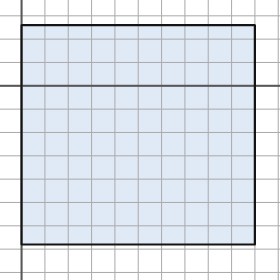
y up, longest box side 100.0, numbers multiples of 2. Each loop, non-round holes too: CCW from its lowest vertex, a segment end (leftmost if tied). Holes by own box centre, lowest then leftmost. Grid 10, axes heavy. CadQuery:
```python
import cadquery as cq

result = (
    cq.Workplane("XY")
    .moveTo(0.0, -68.0)
    .lineTo(100.0, -68.0)
    .lineTo(100.0, 26.0)
    .lineTo(0.0, 26.0)
    .close()
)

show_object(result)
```